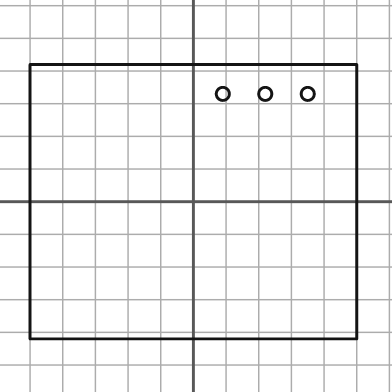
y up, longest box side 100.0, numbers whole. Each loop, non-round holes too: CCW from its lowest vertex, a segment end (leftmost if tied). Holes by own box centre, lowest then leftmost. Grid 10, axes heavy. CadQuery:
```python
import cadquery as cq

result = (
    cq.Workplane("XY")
    .moveTo(-50.0, -42.0)
    .lineTo(50.0, -42.0)
    .lineTo(50.0, 42.0)
    .lineTo(-50.0, 42.0)
    .close()
    .moveTo(9.0, 33.0)
    .circle(2.0)
    .moveTo(22.0, 33.0)
    .circle(2.0)
    .moveTo(35.0, 33.0)
    .circle(2.0)
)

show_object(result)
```